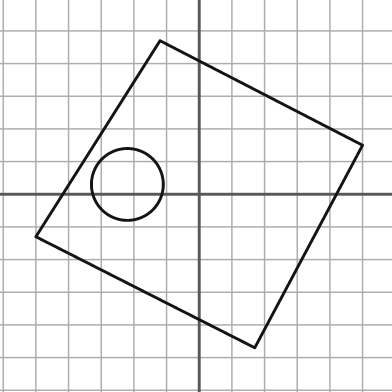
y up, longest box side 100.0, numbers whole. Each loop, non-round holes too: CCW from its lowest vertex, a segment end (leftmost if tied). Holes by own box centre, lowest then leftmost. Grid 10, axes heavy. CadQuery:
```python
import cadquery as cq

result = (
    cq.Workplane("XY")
    .moveTo(17.0, -47.0)
    .lineTo(50.0, 15.0)
    .lineTo(-12.0, 47.0)
    .lineTo(-50.0, -13.0)
    .close()
    .moveTo(-22.0, 3.0)
    .circle(11.0)
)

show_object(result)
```